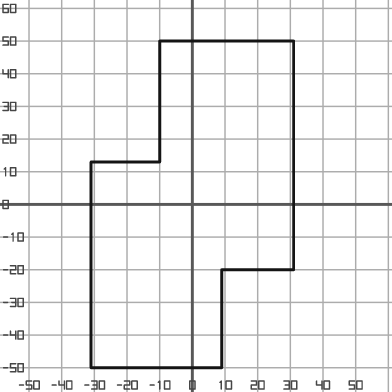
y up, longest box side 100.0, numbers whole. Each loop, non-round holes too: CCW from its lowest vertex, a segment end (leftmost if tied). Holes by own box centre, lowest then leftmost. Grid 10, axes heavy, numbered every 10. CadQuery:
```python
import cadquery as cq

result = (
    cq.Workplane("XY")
    .moveTo(-31.0, -50.0)
    .lineTo(9.0, -50.0)
    .lineTo(9.0, -20.0)
    .lineTo(31.0, -20.0)
    .lineTo(31.0, 50.0)
    .lineTo(-10.0, 50.0)
    .lineTo(-10.0, 13.0)
    .lineTo(-31.0, 13.0)
    .close()
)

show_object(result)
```